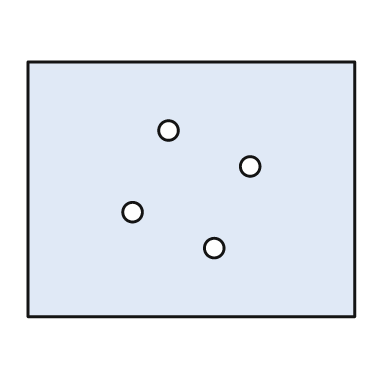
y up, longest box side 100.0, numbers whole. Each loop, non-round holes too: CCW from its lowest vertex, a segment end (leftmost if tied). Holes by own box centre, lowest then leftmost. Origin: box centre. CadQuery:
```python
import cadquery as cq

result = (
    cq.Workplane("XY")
    .moveTo(-50.0, -39.0)
    .lineTo(50.0, -39.0)
    .lineTo(50.0, 39.0)
    .lineTo(-50.0, 39.0)
    .close()
    .moveTo(7.0, -18.0)
    .circle(3.0)
    .moveTo(-18.0, -7.0)
    .circle(3.0)
    .moveTo(18.0, 7.0)
    .circle(3.0)
    .moveTo(-7.0, 18.0)
    .circle(3.0)
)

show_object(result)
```